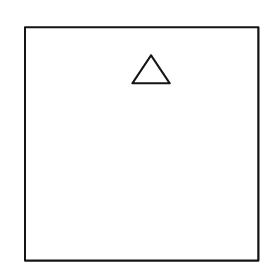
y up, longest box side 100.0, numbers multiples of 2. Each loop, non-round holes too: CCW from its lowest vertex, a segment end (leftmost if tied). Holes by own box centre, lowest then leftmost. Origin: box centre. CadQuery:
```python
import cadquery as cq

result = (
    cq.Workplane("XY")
    .moveTo(-50.0, -50.0)
    .lineTo(50.0, -50.0)
    .lineTo(50.0, 50.0)
    .lineTo(-50.0, 50.0)
    .close()
    .moveTo(-4.0, 26.0)
    .lineTo(12.0, 26.0)
    .lineTo(4.0, 38.0)
    .close()
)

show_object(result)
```